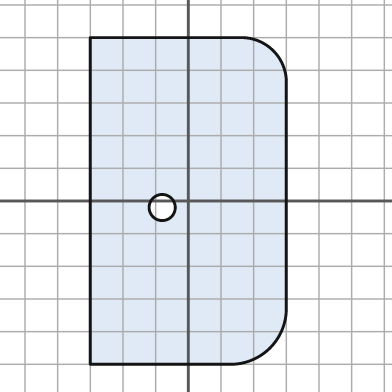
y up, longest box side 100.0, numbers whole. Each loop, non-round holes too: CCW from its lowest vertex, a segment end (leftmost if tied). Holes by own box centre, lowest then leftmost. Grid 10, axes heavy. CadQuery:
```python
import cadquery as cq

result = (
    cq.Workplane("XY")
    .moveTo(-30.0, -50.0)
    .lineTo(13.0, -50.0)
    .threePointArc((25.0, -45.0), (30.0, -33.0))
    .lineTo(30.0, 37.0)
    .threePointArc((26.0, 46.0), (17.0, 50.0))
    .lineTo(-30.0, 50.0)
    .close()
    .moveTo(-8.0, -2.0)
    .circle(4.0)
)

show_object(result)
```